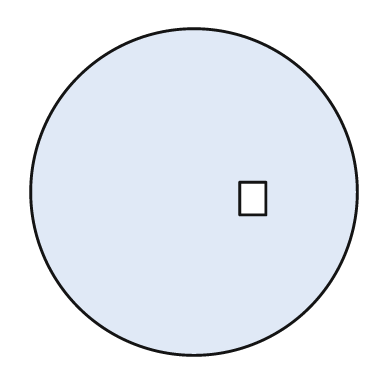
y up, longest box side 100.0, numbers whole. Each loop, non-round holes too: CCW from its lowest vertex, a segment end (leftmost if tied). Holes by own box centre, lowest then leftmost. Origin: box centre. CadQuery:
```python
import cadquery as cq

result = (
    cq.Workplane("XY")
    .moveTo(0.0, 0.0)
    .circle(50.0)
    .moveTo(14.0, -7.0)
    .lineTo(22.0, -7.0)
    .lineTo(22.0, 3.0)
    .lineTo(14.0, 3.0)
    .close()
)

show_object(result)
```